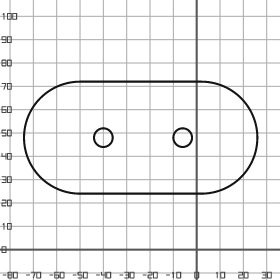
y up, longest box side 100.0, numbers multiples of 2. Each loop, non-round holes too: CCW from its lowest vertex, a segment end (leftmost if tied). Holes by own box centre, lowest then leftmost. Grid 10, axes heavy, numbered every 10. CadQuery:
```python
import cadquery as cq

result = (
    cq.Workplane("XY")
    .moveTo(-50.0, 24.0)
    .lineTo(2.0, 24.0)
    .threePointArc((26.0, 48.0), (2.0, 72.0))
    .lineTo(-50.0, 72.0)
    .threePointArc((-74.0, 48.0), (-50.0, 24.0))
    .close()
    .moveTo(-40.0, 48.0)
    .circle(4.0)
    .moveTo(-6.0, 48.0)
    .circle(4.0)
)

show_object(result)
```